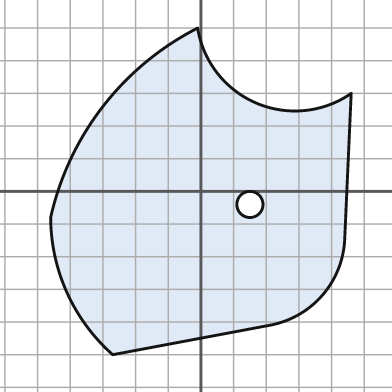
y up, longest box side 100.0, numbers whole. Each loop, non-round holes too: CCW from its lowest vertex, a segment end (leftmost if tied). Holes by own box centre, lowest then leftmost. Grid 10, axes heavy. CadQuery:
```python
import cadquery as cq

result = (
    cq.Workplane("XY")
    .moveTo(-27.0, -50.0)
    .lineTo(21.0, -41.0)
    .threePointArc((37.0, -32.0), (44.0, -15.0))
    .lineTo(46.0, 30.0)
    .threePointArc((17.0, 27.0), (-1.0, 50.0))
    .threePointArc((-30.0, 26.0), (-46.0, -8.0))
    .threePointArc((-41.0, -31.0), (-27.0, -50.0))
    .close()
    .moveTo(15.0, -4.0)
    .circle(4.0)
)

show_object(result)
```